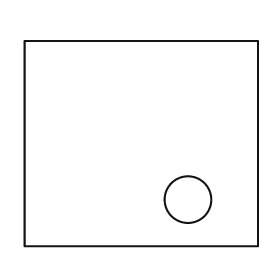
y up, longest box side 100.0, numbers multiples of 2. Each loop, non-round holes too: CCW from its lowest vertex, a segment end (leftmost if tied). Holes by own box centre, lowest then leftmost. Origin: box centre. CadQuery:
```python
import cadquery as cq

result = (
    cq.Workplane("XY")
    .moveTo(-50.0, -44.0)
    .lineTo(50.0, -44.0)
    .lineTo(50.0, 44.0)
    .lineTo(-50.0, 44.0)
    .close()
    .moveTo(20.0, -24.0)
    .circle(10.0)
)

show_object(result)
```